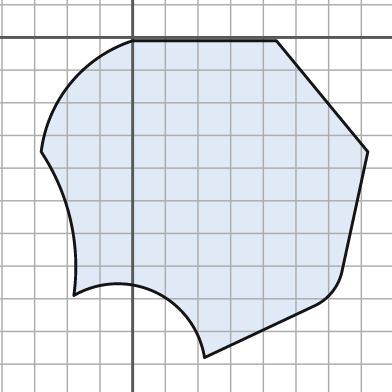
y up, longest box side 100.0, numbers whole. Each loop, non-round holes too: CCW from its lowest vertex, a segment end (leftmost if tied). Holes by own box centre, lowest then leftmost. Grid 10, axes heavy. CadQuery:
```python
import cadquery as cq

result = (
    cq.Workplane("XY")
    .moveTo(22.0, -98.0)
    .lineTo(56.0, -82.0)
    .threePointArc((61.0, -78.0), (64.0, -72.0))
    .lineTo(72.0, -35.0)
    .lineTo(44.0, -1.0)
    .lineTo(0.0, -1.0)
    .threePointArc((-19.0, -14.0), (-28.0, -35.0))
    .threePointArc((-19.0, -56.0), (-18.0, -79.0))
    .threePointArc((7.0, -78.0), (22.0, -98.0))
    .close()
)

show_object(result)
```